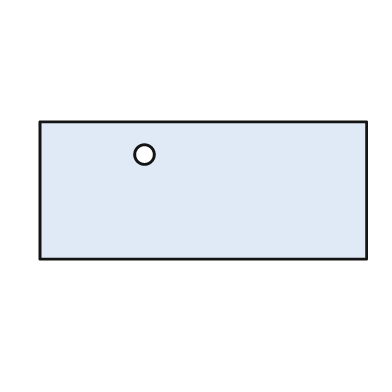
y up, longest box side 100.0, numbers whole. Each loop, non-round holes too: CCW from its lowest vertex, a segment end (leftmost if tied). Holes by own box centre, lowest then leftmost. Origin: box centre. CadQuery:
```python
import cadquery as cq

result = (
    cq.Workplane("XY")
    .moveTo(-50.0, -21.0)
    .lineTo(50.0, -21.0)
    .lineTo(50.0, 21.0)
    .lineTo(-50.0, 21.0)
    .close()
    .moveTo(-18.0, 11.0)
    .circle(3.0)
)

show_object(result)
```